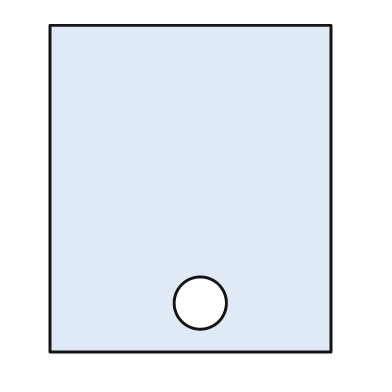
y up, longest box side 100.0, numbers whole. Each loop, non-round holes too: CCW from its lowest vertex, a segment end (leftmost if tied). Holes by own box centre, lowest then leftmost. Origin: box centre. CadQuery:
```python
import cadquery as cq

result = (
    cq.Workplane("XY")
    .moveTo(-43.0, -50.0)
    .lineTo(43.0, -50.0)
    .lineTo(43.0, 50.0)
    .lineTo(-43.0, 50.0)
    .close()
    .moveTo(3.0, -35.0)
    .circle(8.0)
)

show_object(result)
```